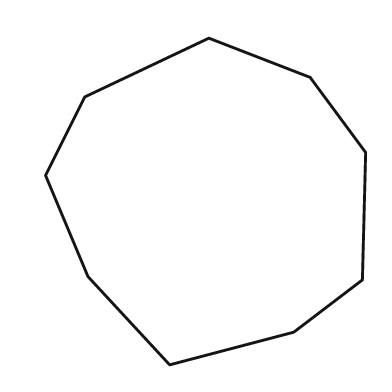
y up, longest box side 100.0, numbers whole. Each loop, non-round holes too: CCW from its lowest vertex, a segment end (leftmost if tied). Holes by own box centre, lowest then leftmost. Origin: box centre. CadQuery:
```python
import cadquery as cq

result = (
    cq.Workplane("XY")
    .moveTo(-11.0, -50.0)
    .lineTo(27.0, -40.0)
    .lineTo(48.0, -24.0)
    .lineTo(49.0, 15.0)
    .lineTo(32.0, 38.0)
    .lineTo(1.0, 50.0)
    .lineTo(-37.0, 32.0)
    .lineTo(-49.0, 8.0)
    .lineTo(-36.0, -23.0)
    .close()
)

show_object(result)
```